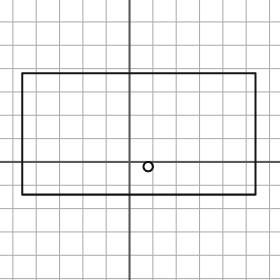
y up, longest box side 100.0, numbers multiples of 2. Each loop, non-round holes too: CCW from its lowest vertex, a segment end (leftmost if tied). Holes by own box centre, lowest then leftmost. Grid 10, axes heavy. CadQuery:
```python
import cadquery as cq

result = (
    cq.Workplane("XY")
    .moveTo(-46.0, -14.0)
    .lineTo(54.0, -14.0)
    .lineTo(54.0, 38.0)
    .lineTo(-46.0, 38.0)
    .close()
    .moveTo(8.0, -2.0)
    .circle(2.0)
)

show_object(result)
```